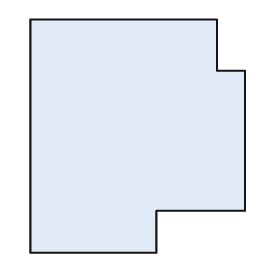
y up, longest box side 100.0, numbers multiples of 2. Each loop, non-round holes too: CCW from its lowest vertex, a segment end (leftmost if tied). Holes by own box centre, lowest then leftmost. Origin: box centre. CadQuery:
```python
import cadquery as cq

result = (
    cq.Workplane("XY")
    .moveTo(-46.0, -50.0)
    .lineTo(8.0, -50.0)
    .lineTo(8.0, -32.0)
    .lineTo(46.0, -32.0)
    .lineTo(46.0, 28.0)
    .lineTo(34.0, 28.0)
    .lineTo(34.0, 50.0)
    .lineTo(-46.0, 50.0)
    .close()
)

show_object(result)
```